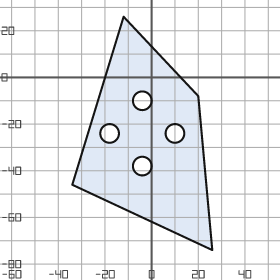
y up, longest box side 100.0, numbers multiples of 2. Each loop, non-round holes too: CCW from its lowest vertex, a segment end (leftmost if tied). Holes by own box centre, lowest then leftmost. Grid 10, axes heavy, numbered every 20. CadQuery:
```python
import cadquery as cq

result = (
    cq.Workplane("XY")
    .moveTo(26.0, -74.0)
    .lineTo(20.0, -8.0)
    .lineTo(-12.0, 26.0)
    .lineTo(-34.0, -46.0)
    .close()
    .moveTo(-4.0, -38.0)
    .circle(4.0)
    .moveTo(-18.0, -24.0)
    .circle(4.0)
    .moveTo(10.0, -24.0)
    .circle(4.0)
    .moveTo(-4.0, -10.0)
    .circle(4.0)
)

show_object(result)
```